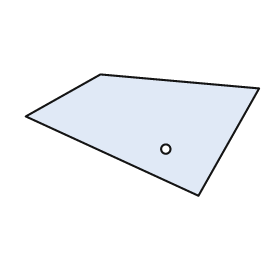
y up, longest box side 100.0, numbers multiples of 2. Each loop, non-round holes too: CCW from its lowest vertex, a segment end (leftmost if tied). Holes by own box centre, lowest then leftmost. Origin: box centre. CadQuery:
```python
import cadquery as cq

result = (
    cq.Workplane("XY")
    .moveTo(24.0, -26.0)
    .lineTo(50.0, 20.0)
    .lineTo(-18.0, 26.0)
    .lineTo(-50.0, 8.0)
    .close()
    .moveTo(10.0, -6.0)
    .circle(2.0)
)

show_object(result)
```